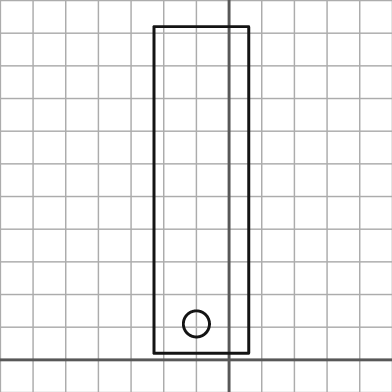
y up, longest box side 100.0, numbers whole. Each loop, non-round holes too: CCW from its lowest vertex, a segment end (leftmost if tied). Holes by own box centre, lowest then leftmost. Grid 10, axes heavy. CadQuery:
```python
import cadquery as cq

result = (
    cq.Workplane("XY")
    .moveTo(-23.0, 2.0)
    .lineTo(6.0, 2.0)
    .lineTo(6.0, 102.0)
    .lineTo(-23.0, 102.0)
    .close()
    .moveTo(-10.0, 11.0)
    .circle(4.0)
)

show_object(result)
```